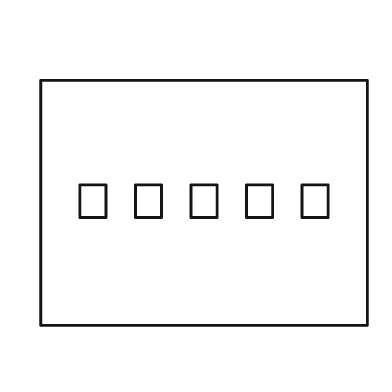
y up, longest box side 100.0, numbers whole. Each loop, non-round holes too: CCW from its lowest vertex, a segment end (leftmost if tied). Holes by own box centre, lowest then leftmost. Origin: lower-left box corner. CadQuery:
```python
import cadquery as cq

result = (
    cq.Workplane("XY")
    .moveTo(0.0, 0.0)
    .lineTo(100.0, 0.0)
    .lineTo(100.0, 75.0)
    .lineTo(0.0, 75.0)
    .close()
    .moveTo(12.0, 33.0)
    .lineTo(20.0, 33.0)
    .lineTo(20.0, 43.0)
    .lineTo(12.0, 43.0)
    .close()
    .moveTo(29.0, 33.0)
    .lineTo(37.0, 33.0)
    .lineTo(37.0, 43.0)
    .lineTo(29.0, 43.0)
    .close()
    .moveTo(46.0, 33.0)
    .lineTo(54.0, 33.0)
    .lineTo(54.0, 43.0)
    .lineTo(46.0, 43.0)
    .close()
    .moveTo(63.0, 33.0)
    .lineTo(71.0, 33.0)
    .lineTo(71.0, 43.0)
    .lineTo(63.0, 43.0)
    .close()
    .moveTo(80.0, 33.0)
    .lineTo(88.0, 33.0)
    .lineTo(88.0, 43.0)
    .lineTo(80.0, 43.0)
    .close()
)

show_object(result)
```